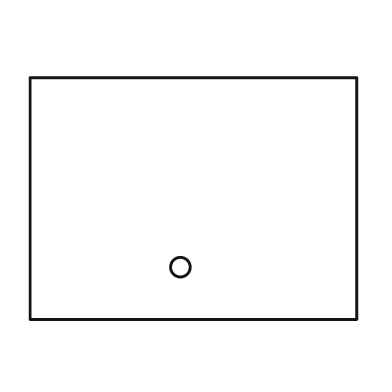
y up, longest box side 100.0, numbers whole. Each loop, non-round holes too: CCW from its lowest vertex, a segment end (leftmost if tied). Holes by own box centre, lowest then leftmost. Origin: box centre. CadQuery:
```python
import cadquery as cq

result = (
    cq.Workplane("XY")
    .moveTo(-50.0, -37.0)
    .lineTo(50.0, -37.0)
    .lineTo(50.0, 37.0)
    .lineTo(-50.0, 37.0)
    .close()
    .moveTo(-4.0, -21.0)
    .circle(3.0)
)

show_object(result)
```